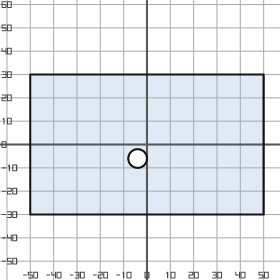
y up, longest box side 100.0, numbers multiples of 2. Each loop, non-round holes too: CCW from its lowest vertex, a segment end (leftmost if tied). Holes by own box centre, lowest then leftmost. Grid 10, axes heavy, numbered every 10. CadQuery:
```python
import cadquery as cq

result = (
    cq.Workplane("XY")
    .moveTo(-50.0, -30.0)
    .lineTo(50.0, -30.0)
    .lineTo(50.0, 30.0)
    .lineTo(-50.0, 30.0)
    .close()
    .moveTo(-4.0, -6.0)
    .circle(4.0)
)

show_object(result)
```